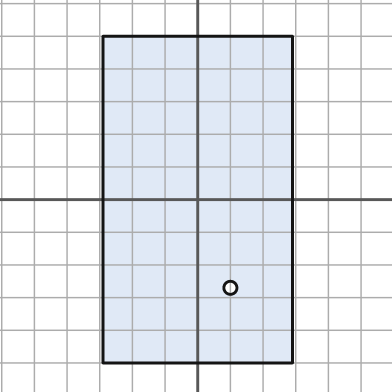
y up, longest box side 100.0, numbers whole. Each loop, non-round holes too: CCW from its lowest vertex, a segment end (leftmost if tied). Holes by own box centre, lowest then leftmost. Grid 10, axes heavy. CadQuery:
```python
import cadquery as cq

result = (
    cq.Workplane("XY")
    .moveTo(-29.0, -50.0)
    .lineTo(29.0, -50.0)
    .lineTo(29.0, 50.0)
    .lineTo(-29.0, 50.0)
    .close()
    .moveTo(10.0, -27.0)
    .circle(2.0)
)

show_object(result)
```